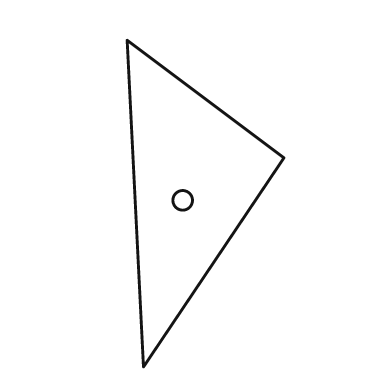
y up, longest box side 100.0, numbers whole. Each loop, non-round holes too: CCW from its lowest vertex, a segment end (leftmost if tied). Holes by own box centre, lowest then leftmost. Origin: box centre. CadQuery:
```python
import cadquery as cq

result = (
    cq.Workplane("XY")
    .moveTo(-19.0, -50.0)
    .lineTo(24.0, 14.0)
    .lineTo(-24.0, 50.0)
    .close()
    .moveTo(-7.0, 1.0)
    .circle(3.0)
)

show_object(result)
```